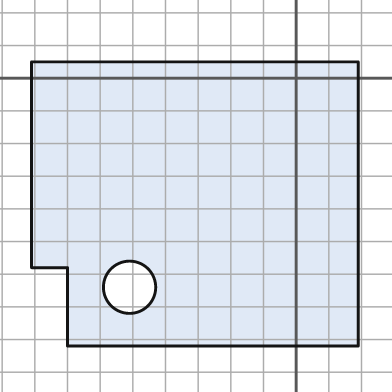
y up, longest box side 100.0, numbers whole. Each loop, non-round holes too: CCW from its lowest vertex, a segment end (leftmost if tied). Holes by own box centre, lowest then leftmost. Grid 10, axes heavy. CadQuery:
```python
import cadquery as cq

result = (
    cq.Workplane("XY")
    .moveTo(-70.0, -82.0)
    .lineTo(19.0, -82.0)
    .lineTo(19.0, 5.0)
    .lineTo(-81.0, 5.0)
    .lineTo(-81.0, -58.0)
    .lineTo(-70.0, -58.0)
    .close()
    .moveTo(-51.0, -64.0)
    .circle(8.0)
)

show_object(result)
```